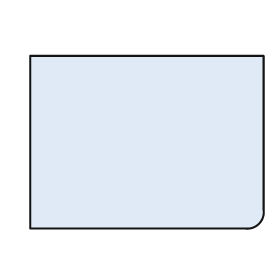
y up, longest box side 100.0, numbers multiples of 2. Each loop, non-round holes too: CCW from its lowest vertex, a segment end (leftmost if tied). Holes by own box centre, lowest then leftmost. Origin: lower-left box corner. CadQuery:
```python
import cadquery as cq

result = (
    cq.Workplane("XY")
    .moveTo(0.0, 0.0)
    .lineTo(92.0, 0.0)
    .threePointArc((98.0, 2.0), (100.0, 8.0))
    .lineTo(100.0, 74.0)
    .lineTo(0.0, 74.0)
    .close()
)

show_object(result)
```